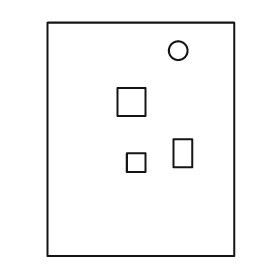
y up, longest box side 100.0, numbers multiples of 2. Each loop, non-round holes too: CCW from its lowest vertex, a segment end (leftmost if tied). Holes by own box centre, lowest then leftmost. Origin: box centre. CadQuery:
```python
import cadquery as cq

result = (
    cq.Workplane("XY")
    .moveTo(-40.0, -50.0)
    .lineTo(40.0, -50.0)
    .lineTo(40.0, 50.0)
    .lineTo(-40.0, 50.0)
    .close()
    .moveTo(-6.0, -14.0)
    .lineTo(2.0, -14.0)
    .lineTo(2.0, -6.0)
    .lineTo(-6.0, -6.0)
    .close()
    .moveTo(14.0, -12.0)
    .lineTo(22.0, -12.0)
    .lineTo(22.0, 0.0)
    .lineTo(14.0, 0.0)
    .close()
    .moveTo(-10.0, 10.0)
    .lineTo(2.0, 10.0)
    .lineTo(2.0, 22.0)
    .lineTo(-10.0, 22.0)
    .close()
    .moveTo(16.0, 38.0)
    .circle(4.0)
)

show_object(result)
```